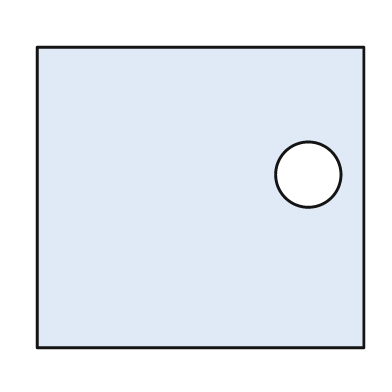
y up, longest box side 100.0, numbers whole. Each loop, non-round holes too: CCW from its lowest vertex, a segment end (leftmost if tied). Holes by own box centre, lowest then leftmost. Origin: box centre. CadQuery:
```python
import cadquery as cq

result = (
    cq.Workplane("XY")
    .moveTo(-50.0, -46.0)
    .lineTo(50.0, -46.0)
    .lineTo(50.0, 46.0)
    .lineTo(-50.0, 46.0)
    .close()
    .moveTo(33.0, 7.0)
    .circle(10.0)
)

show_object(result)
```